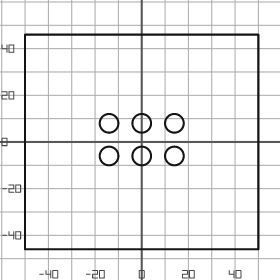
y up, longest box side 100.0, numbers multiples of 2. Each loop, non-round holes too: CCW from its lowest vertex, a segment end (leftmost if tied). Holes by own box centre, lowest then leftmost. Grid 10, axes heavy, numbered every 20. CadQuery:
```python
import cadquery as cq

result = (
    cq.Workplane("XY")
    .moveTo(-50.0, -46.0)
    .lineTo(50.0, -46.0)
    .lineTo(50.0, 46.0)
    .lineTo(-50.0, 46.0)
    .close()
    .moveTo(-14.0, -6.0)
    .circle(4.0)
    .moveTo(0.0, -6.0)
    .circle(4.0)
    .moveTo(14.0, -6.0)
    .circle(4.0)
    .moveTo(-14.0, 8.0)
    .circle(4.0)
    .moveTo(0.0, 8.0)
    .circle(4.0)
    .moveTo(14.0, 8.0)
    .circle(4.0)
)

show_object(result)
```